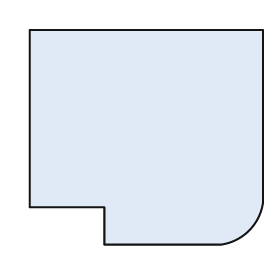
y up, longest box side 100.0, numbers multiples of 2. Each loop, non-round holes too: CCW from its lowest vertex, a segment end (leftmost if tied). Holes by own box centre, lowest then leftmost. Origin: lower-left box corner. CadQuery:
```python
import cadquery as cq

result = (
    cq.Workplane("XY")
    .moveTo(32.0, 0.0)
    .lineTo(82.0, 0.0)
    .threePointArc((94.0, 6.0), (100.0, 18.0))
    .lineTo(100.0, 92.0)
    .lineTo(0.0, 92.0)
    .lineTo(0.0, 16.0)
    .lineTo(32.0, 16.0)
    .close()
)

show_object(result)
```